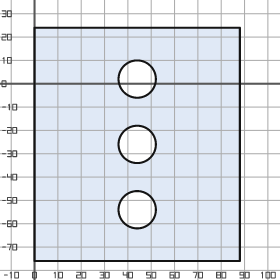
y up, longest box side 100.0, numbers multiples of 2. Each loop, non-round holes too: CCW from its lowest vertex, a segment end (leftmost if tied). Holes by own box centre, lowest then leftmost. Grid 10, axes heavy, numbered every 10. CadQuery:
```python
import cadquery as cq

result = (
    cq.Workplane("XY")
    .moveTo(0.0, -76.0)
    .lineTo(88.0, -76.0)
    .lineTo(88.0, 24.0)
    .lineTo(0.0, 24.0)
    .close()
    .moveTo(44.0, -54.0)
    .circle(8.0)
    .moveTo(44.0, -26.0)
    .circle(8.0)
    .moveTo(44.0, 2.0)
    .circle(8.0)
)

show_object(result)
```